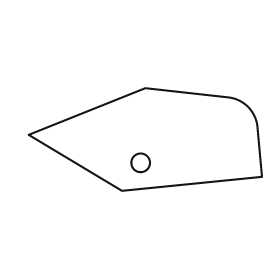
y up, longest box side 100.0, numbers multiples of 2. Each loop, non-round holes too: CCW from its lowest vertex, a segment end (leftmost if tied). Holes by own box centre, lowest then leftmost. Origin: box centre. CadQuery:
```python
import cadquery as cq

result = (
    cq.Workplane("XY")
    .moveTo(-10.0, -22.0)
    .lineTo(50.0, -16.0)
    .lineTo(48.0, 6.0)
    .threePointArc((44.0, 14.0), (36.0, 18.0))
    .lineTo(0.0, 22.0)
    .lineTo(-50.0, 2.0)
    .close()
    .moveTo(-2.0, -10.0)
    .circle(4.0)
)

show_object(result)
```